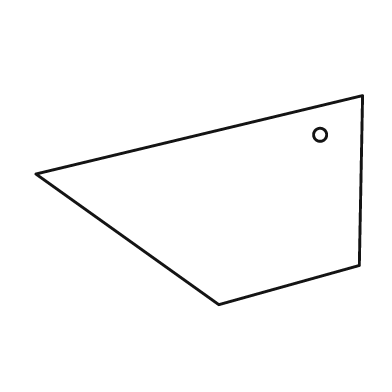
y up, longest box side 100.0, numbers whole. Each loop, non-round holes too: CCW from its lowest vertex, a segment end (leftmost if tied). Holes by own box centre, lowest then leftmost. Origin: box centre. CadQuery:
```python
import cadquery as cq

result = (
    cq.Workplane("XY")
    .moveTo(6.0, -32.0)
    .lineTo(49.0, -20.0)
    .lineTo(50.0, 32.0)
    .lineTo(-50.0, 8.0)
    .close()
    .moveTo(37.0, 20.0)
    .circle(2.0)
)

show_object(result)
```